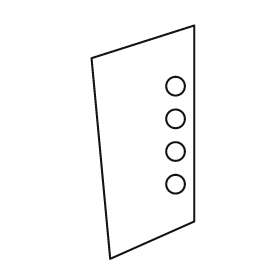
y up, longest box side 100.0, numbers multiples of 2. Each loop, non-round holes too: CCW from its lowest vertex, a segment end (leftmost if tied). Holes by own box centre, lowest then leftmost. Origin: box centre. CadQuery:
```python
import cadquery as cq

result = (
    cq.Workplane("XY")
    .moveTo(-14.0, -50.0)
    .lineTo(22.0, -34.0)
    .lineTo(22.0, 50.0)
    .lineTo(-22.0, 36.0)
    .close()
    .moveTo(14.0, -18.0)
    .circle(4.0)
    .moveTo(14.0, -4.0)
    .circle(4.0)
    .moveTo(14.0, 10.0)
    .circle(4.0)
    .moveTo(14.0, 24.0)
    .circle(4.0)
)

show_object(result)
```